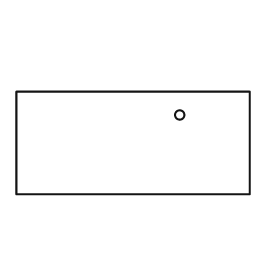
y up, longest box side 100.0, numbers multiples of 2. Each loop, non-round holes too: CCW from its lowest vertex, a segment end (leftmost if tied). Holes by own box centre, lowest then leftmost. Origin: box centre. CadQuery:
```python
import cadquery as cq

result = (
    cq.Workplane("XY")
    .moveTo(-50.0, -22.0)
    .lineTo(50.0, -22.0)
    .lineTo(50.0, 22.0)
    .lineTo(-50.0, 22.0)
    .close()
    .moveTo(20.0, 12.0)
    .circle(2.0)
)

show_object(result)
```